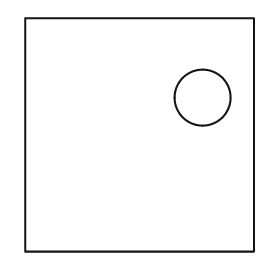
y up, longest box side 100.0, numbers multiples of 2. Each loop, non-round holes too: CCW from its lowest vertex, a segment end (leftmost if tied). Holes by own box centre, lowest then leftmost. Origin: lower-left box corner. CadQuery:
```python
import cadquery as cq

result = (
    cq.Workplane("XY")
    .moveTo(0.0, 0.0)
    .lineTo(98.0, 0.0)
    .lineTo(98.0, 100.0)
    .lineTo(0.0, 100.0)
    .close()
    .moveTo(76.0, 66.0)
    .circle(12.0)
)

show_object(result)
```